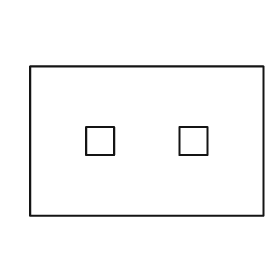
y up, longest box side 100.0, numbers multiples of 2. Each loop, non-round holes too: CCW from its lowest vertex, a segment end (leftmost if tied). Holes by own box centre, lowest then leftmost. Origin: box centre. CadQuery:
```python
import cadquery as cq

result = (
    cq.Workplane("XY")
    .moveTo(-50.0, -32.0)
    .lineTo(50.0, -32.0)
    .lineTo(50.0, 32.0)
    .lineTo(-50.0, 32.0)
    .close()
    .moveTo(-26.0, -6.0)
    .lineTo(-14.0, -6.0)
    .lineTo(-14.0, 6.0)
    .lineTo(-26.0, 6.0)
    .close()
    .moveTo(14.0, -6.0)
    .lineTo(26.0, -6.0)
    .lineTo(26.0, 6.0)
    .lineTo(14.0, 6.0)
    .close()
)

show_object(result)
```